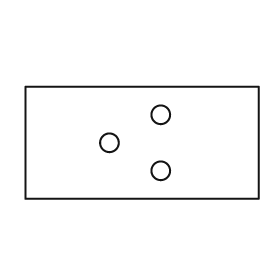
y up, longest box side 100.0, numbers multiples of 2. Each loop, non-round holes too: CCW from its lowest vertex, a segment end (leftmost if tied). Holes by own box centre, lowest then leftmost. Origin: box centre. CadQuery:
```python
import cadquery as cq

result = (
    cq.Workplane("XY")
    .moveTo(-50.0, -24.0)
    .lineTo(50.0, -24.0)
    .lineTo(50.0, 24.0)
    .lineTo(-50.0, 24.0)
    .close()
    .moveTo(8.0, -12.0)
    .circle(4.0)
    .moveTo(-14.0, 0.0)
    .circle(4.0)
    .moveTo(8.0, 12.0)
    .circle(4.0)
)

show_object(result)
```